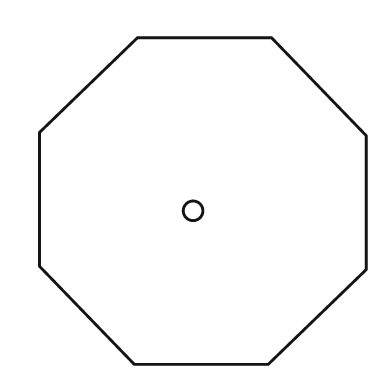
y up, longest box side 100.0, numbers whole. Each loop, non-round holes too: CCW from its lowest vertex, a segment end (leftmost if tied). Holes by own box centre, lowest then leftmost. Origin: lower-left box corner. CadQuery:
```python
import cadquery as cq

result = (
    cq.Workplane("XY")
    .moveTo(29.0, 0.0)
    .lineTo(70.0, 0.0)
    .lineTo(100.0, 29.0)
    .lineTo(100.0, 70.0)
    .lineTo(71.0, 100.0)
    .lineTo(30.0, 100.0)
    .lineTo(0.0, 71.0)
    .lineTo(0.0, 30.0)
    .close()
    .moveTo(47.0, 47.0)
    .circle(3.0)
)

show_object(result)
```